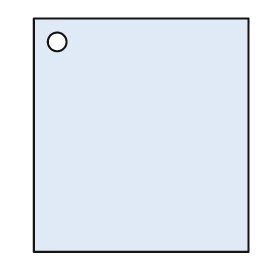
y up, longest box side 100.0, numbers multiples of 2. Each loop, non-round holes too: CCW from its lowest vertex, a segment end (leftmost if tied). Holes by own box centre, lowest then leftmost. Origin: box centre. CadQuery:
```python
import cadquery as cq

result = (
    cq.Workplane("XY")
    .moveTo(-46.0, -50.0)
    .lineTo(46.0, -50.0)
    .lineTo(46.0, 50.0)
    .lineTo(-46.0, 50.0)
    .close()
    .moveTo(-36.0, 40.0)
    .circle(4.0)
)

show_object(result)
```